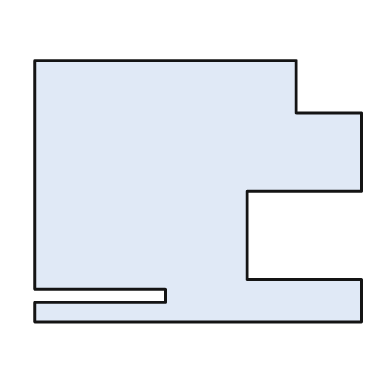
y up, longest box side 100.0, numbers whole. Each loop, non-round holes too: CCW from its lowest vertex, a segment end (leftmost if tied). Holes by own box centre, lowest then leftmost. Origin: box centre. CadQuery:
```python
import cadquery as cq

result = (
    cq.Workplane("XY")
    .moveTo(-50.0, -40.0)
    .lineTo(50.0, -40.0)
    .lineTo(50.0, -27.0)
    .lineTo(15.0, -27.0)
    .lineTo(15.0, 0.0)
    .lineTo(50.0, 0.0)
    .lineTo(50.0, 24.0)
    .lineTo(30.0, 24.0)
    .lineTo(30.0, 40.0)
    .lineTo(-50.0, 40.0)
    .lineTo(-50.0, -30.0)
    .lineTo(-10.0, -30.0)
    .lineTo(-10.0, -34.0)
    .lineTo(-50.0, -34.0)
    .close()
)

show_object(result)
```